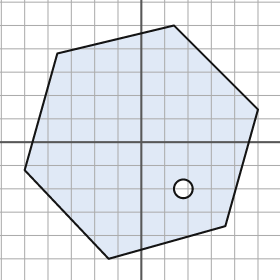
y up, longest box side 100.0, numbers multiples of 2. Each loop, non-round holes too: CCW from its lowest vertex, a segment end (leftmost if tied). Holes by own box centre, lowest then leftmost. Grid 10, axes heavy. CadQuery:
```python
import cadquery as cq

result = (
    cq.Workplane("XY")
    .moveTo(-14.0, -50.0)
    .lineTo(36.0, -36.0)
    .lineTo(50.0, 14.0)
    .lineTo(14.0, 50.0)
    .lineTo(-36.0, 38.0)
    .lineTo(-50.0, -12.0)
    .close()
    .moveTo(18.0, -20.0)
    .circle(4.0)
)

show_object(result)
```